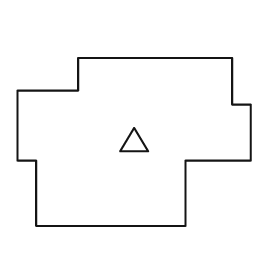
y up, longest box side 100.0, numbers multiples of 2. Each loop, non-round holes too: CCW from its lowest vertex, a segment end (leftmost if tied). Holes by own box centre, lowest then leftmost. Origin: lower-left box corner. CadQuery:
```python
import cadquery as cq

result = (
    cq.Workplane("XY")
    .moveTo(8.0, 0.0)
    .lineTo(72.0, 0.0)
    .lineTo(72.0, 28.0)
    .lineTo(100.0, 28.0)
    .lineTo(100.0, 52.0)
    .lineTo(92.0, 52.0)
    .lineTo(92.0, 72.0)
    .lineTo(26.0, 72.0)
    .lineTo(26.0, 58.0)
    .lineTo(0.0, 58.0)
    .lineTo(0.0, 28.0)
    .lineTo(8.0, 28.0)
    .close()
    .moveTo(44.0, 32.0)
    .lineTo(56.0, 32.0)
    .lineTo(50.0, 42.0)
    .close()
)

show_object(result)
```